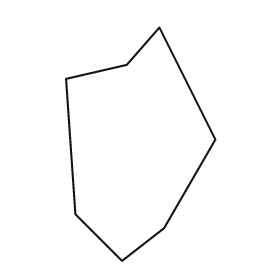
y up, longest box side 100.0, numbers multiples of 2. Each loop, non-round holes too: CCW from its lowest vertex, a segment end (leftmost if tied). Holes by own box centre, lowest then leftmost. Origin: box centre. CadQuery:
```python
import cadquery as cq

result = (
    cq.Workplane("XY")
    .moveTo(-8.0, -50.0)
    .lineTo(10.0, -36.0)
    .lineTo(32.0, 2.0)
    .lineTo(8.0, 50.0)
    .lineTo(-6.0, 34.0)
    .lineTo(-32.0, 28.0)
    .lineTo(-28.0, -30.0)
    .close()
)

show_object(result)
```